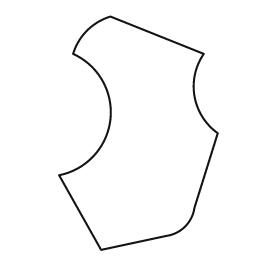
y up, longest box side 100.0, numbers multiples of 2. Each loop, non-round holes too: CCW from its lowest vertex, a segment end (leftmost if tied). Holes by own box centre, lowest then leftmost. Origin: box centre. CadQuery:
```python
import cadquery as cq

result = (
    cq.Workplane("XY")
    .moveTo(-16.0, -50.0)
    .lineTo(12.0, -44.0)
    .threePointArc((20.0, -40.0), (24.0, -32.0))
    .lineTo(34.0, 0.0)
    .threePointArc((24.0, 16.0), (28.0, 34.0))
    .lineTo(-12.0, 50.0)
    .threePointArc((-22.0, 44.0), (-28.0, 34.0))
    .threePointArc((-12.0, 6.0), (-34.0, -18.0))
    .close()
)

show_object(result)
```